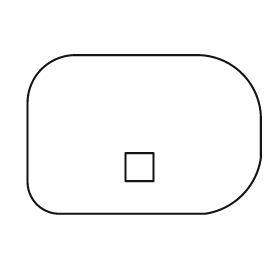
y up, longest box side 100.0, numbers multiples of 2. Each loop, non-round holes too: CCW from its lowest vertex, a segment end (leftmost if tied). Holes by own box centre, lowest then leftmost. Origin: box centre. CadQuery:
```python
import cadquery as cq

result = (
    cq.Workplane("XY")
    .moveTo(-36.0, -34.0)
    .lineTo(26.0, -34.0)
    .threePointArc((42.0, -26.0), (50.0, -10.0))
    .lineTo(50.0, 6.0)
    .threePointArc((42.0, 26.0), (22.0, 34.0))
    .lineTo(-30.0, 34.0)
    .threePointArc((-44.0, 28.0), (-50.0, 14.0))
    .lineTo(-50.0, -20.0)
    .threePointArc((-46.0, -30.0), (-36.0, -34.0))
    .close()
    .moveTo(-8.0, -20.0)
    .lineTo(4.0, -20.0)
    .lineTo(4.0, -8.0)
    .lineTo(-8.0, -8.0)
    .close()
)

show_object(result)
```